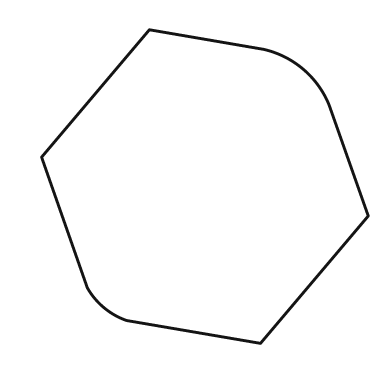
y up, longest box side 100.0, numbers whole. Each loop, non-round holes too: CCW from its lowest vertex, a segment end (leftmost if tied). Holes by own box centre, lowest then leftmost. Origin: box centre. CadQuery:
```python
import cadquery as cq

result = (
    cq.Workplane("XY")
    .moveTo(17.0, -48.0)
    .lineTo(50.0, -9.0)
    .lineTo(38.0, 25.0)
    .threePointArc((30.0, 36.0), (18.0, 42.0))
    .lineTo(-17.0, 48.0)
    .lineTo(-50.0, 9.0)
    .lineTo(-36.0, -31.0)
    .threePointArc((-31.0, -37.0), (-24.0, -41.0))
    .close()
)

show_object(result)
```